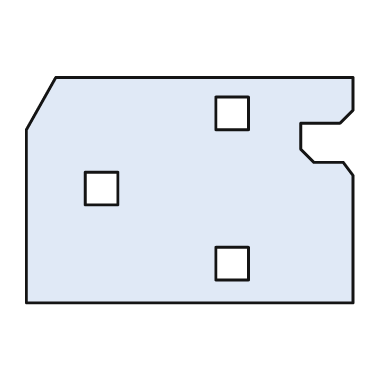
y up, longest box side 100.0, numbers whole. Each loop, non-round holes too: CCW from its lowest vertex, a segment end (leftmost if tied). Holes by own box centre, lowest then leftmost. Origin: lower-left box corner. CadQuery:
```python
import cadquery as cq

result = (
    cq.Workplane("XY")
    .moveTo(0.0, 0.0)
    .lineTo(100.0, 0.0)
    .lineTo(100.0, 39.0)
    .lineTo(97.0, 43.0)
    .lineTo(88.0, 43.0)
    .lineTo(84.0, 47.0)
    .lineTo(84.0, 55.0)
    .lineTo(96.0, 55.0)
    .lineTo(100.0, 59.0)
    .lineTo(100.0, 69.0)
    .lineTo(9.0, 69.0)
    .lineTo(0.0, 53.0)
    .close()
    .moveTo(58.0, 7.0)
    .lineTo(68.0, 7.0)
    .lineTo(68.0, 17.0)
    .lineTo(58.0, 17.0)
    .close()
    .moveTo(18.0, 30.0)
    .lineTo(28.0, 30.0)
    .lineTo(28.0, 40.0)
    .lineTo(18.0, 40.0)
    .close()
    .moveTo(58.0, 53.0)
    .lineTo(68.0, 53.0)
    .lineTo(68.0, 63.0)
    .lineTo(58.0, 63.0)
    .close()
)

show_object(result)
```